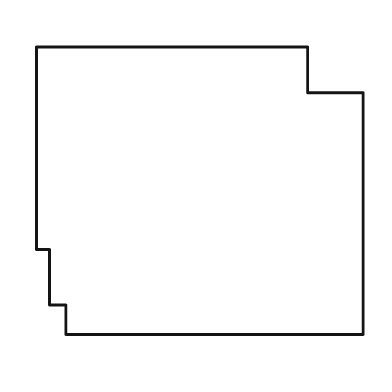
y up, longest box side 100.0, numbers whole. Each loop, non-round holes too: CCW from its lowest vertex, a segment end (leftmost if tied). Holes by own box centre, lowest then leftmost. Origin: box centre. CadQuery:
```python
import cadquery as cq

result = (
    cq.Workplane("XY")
    .moveTo(-41.0, -44.0)
    .lineTo(50.0, -44.0)
    .lineTo(50.0, 30.0)
    .lineTo(33.0, 30.0)
    .lineTo(33.0, 44.0)
    .lineTo(-50.0, 44.0)
    .lineTo(-50.0, -18.0)
    .lineTo(-46.0, -18.0)
    .lineTo(-46.0, -35.0)
    .lineTo(-41.0, -35.0)
    .close()
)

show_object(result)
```